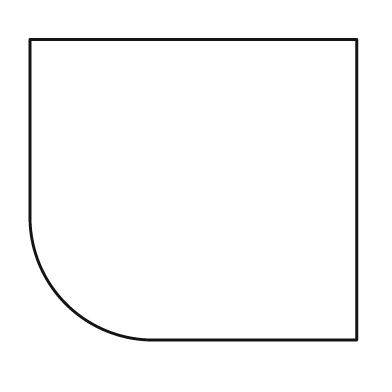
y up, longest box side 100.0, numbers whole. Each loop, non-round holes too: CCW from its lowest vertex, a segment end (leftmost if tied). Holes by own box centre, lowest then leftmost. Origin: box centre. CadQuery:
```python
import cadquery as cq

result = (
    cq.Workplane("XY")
    .moveTo(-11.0, -46.0)
    .lineTo(50.0, -46.0)
    .lineTo(50.0, 46.0)
    .lineTo(-50.0, 46.0)
    .lineTo(-50.0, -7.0)
    .threePointArc((-39.0, -35.0), (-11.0, -46.0))
    .close()
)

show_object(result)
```